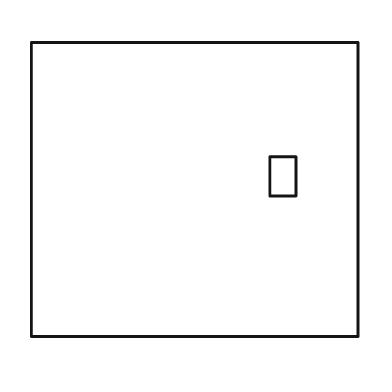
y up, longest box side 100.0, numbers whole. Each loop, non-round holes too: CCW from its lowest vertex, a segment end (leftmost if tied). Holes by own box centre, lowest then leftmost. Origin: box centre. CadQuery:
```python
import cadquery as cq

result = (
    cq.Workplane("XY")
    .moveTo(-50.0, -45.0)
    .lineTo(50.0, -45.0)
    .lineTo(50.0, 45.0)
    .lineTo(-50.0, 45.0)
    .close()
    .moveTo(23.0, -2.0)
    .lineTo(31.0, -2.0)
    .lineTo(31.0, 10.0)
    .lineTo(23.0, 10.0)
    .close()
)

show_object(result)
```